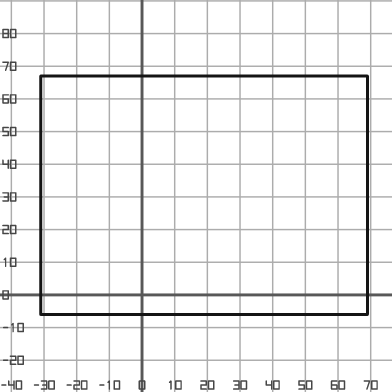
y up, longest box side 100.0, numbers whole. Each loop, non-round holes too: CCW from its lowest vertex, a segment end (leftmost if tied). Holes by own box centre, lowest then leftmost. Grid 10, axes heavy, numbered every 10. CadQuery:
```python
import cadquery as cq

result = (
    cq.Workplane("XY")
    .moveTo(-31.0, -6.0)
    .lineTo(69.0, -6.0)
    .lineTo(69.0, 67.0)
    .lineTo(-31.0, 67.0)
    .close()
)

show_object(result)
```